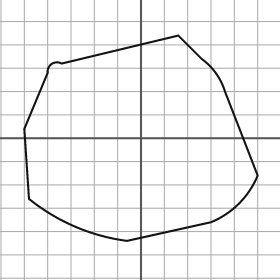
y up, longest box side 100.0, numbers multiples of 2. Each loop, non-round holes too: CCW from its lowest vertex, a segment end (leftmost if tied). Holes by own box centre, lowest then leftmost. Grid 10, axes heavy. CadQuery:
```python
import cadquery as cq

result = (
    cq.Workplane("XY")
    .moveTo(-6.0, -44.0)
    .lineTo(30.0, -36.0)
    .threePointArc((42.0, -28.0), (50.0, -16.0))
    .lineTo(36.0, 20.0)
    .threePointArc((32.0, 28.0), (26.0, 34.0))
    .lineTo(16.0, 44.0)
    .lineTo(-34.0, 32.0)
    .threePointArc((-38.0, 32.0), (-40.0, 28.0))
    .lineTo(-50.0, 4.0)
    .lineTo(-48.0, -26.0)
    .threePointArc((-28.0, -38.0), (-6.0, -44.0))
    .close()
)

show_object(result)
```